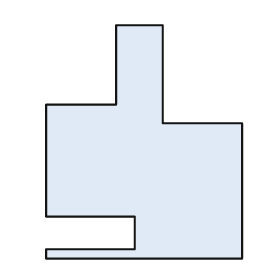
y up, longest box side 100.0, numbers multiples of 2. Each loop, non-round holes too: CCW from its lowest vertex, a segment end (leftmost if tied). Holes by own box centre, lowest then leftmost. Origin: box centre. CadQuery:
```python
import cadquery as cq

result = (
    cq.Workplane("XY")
    .moveTo(-42.0, -50.0)
    .lineTo(42.0, -50.0)
    .lineTo(42.0, 8.0)
    .lineTo(8.0, 8.0)
    .lineTo(8.0, 50.0)
    .lineTo(-12.0, 50.0)
    .lineTo(-12.0, 16.0)
    .lineTo(-42.0, 16.0)
    .lineTo(-42.0, -32.0)
    .lineTo(-4.0, -32.0)
    .lineTo(-4.0, -46.0)
    .lineTo(-42.0, -46.0)
    .close()
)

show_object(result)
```